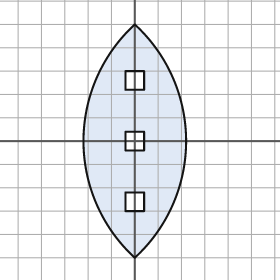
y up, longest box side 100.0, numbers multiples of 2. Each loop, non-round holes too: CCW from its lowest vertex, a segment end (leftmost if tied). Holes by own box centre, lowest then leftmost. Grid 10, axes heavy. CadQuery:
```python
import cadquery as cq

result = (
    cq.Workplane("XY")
    .moveTo(0.0, -50.0)
    .threePointArc((22.0, 0.0), (0.0, 50.0))
    .threePointArc((-22.0, 0.0), (0.0, -50.0))
    .close()
    .moveTo(-4.0, -30.0)
    .lineTo(4.0, -30.0)
    .lineTo(4.0, -22.0)
    .lineTo(-4.0, -22.0)
    .close()
    .moveTo(-4.0, -4.0)
    .lineTo(4.0, -4.0)
    .lineTo(4.0, 4.0)
    .lineTo(-4.0, 4.0)
    .close()
    .moveTo(-4.0, 22.0)
    .lineTo(4.0, 22.0)
    .lineTo(4.0, 30.0)
    .lineTo(-4.0, 30.0)
    .close()
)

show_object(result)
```